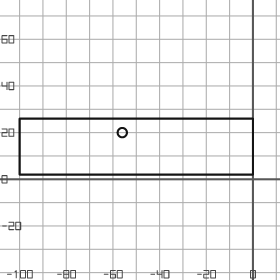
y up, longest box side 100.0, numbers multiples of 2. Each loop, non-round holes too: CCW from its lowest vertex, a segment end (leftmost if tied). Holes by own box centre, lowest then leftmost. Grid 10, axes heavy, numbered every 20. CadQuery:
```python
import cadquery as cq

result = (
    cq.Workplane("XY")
    .moveTo(-100.0, 2.0)
    .lineTo(0.0, 2.0)
    .lineTo(0.0, 26.0)
    .lineTo(-100.0, 26.0)
    .close()
    .moveTo(-56.0, 20.0)
    .circle(2.0)
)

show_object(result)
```